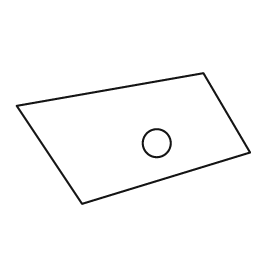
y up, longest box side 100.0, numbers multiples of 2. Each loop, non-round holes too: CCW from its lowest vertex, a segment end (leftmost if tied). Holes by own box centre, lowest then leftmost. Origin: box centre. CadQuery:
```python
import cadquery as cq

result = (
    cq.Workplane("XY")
    .moveTo(-22.0, -28.0)
    .lineTo(50.0, -6.0)
    .lineTo(30.0, 28.0)
    .lineTo(-50.0, 14.0)
    .close()
    .moveTo(10.0, -2.0)
    .circle(6.0)
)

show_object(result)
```